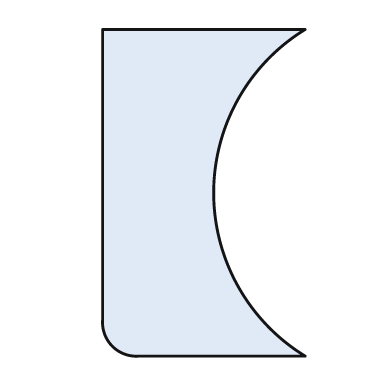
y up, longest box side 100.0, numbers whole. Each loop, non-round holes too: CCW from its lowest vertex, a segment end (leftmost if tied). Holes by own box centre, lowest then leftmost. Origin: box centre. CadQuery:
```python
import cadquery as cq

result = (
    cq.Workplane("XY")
    .moveTo(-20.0, -50.0)
    .lineTo(31.0, -50.0)
    .threePointArc((3.0, 0.0), (31.0, 50.0))
    .lineTo(-31.0, 50.0)
    .lineTo(-31.0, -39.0)
    .threePointArc((-28.0, -47.0), (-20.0, -50.0))
    .close()
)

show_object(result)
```